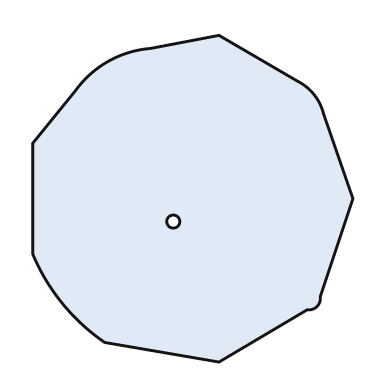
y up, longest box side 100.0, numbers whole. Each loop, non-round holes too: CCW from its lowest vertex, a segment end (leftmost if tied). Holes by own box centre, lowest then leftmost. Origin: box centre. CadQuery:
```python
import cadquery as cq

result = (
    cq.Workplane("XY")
    .moveTo(8.0, -50.0)
    .lineTo(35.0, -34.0)
    .threePointArc((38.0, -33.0), (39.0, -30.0))
    .lineTo(49.0, 0.0)
    .lineTo(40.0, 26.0)
    .threePointArc((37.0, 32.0), (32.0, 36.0))
    .lineTo(8.0, 50.0)
    .lineTo(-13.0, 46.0)
    .threePointArc((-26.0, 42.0), (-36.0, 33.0))
    .lineTo(-49.0, 17.0)
    .lineTo(-49.0, -17.0)
    .threePointArc((-40.0, -32.0), (-27.0, -44.0))
    .close()
    .moveTo(-6.0, -7.0)
    .circle(2.0)
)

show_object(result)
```